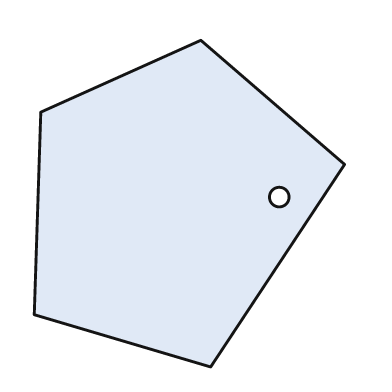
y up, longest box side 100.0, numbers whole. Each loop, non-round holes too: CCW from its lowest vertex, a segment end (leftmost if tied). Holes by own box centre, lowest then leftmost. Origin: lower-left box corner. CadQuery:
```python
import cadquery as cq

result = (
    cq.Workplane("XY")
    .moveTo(54.0, 0.0)
    .lineTo(95.0, 62.0)
    .lineTo(51.0, 100.0)
    .lineTo(2.0, 78.0)
    .lineTo(0.0, 16.0)
    .close()
    .moveTo(75.0, 52.0)
    .circle(3.0)
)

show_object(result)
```